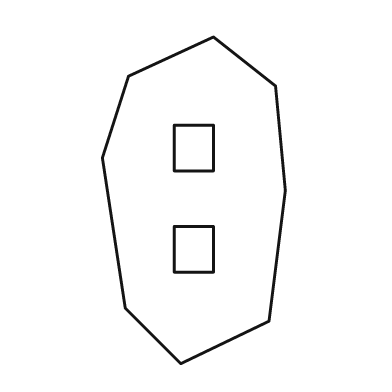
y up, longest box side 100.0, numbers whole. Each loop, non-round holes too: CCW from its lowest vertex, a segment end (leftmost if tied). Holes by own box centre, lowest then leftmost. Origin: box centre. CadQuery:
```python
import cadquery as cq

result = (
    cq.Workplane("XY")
    .moveTo(-4.0, -50.0)
    .lineTo(23.0, -37.0)
    .lineTo(28.0, 3.0)
    .lineTo(25.0, 35.0)
    .lineTo(6.0, 50.0)
    .lineTo(-20.0, 38.0)
    .lineTo(-28.0, 13.0)
    .lineTo(-21.0, -33.0)
    .close()
    .moveTo(-6.0, -22.0)
    .lineTo(6.0, -22.0)
    .lineTo(6.0, -8.0)
    .lineTo(-6.0, -8.0)
    .close()
    .moveTo(-6.0, 9.0)
    .lineTo(6.0, 9.0)
    .lineTo(6.0, 23.0)
    .lineTo(-6.0, 23.0)
    .close()
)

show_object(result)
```